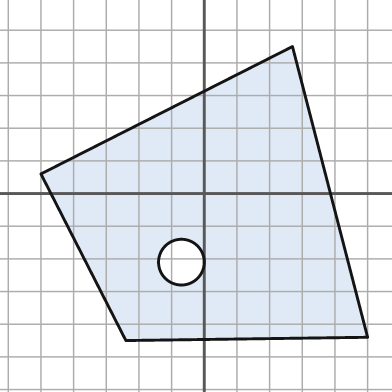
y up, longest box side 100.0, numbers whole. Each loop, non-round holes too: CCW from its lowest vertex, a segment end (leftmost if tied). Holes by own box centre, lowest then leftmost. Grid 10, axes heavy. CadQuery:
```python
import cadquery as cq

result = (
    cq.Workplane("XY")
    .moveTo(-24.0, -45.0)
    .lineTo(50.0, -44.0)
    .lineTo(27.0, 45.0)
    .lineTo(-50.0, 6.0)
    .close()
    .moveTo(-7.0, -21.0)
    .circle(7.0)
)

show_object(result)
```